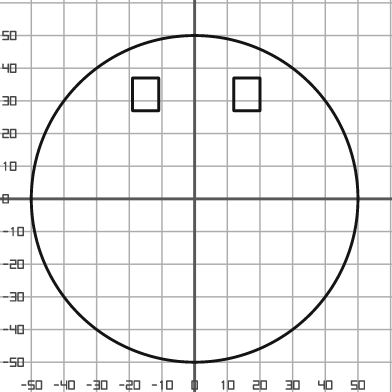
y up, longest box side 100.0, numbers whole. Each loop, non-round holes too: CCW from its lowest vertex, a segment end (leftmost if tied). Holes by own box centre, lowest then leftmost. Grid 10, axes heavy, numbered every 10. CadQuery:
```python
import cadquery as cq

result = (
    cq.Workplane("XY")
    .moveTo(0.0, 0.0)
    .circle(50.0)
    .moveTo(-19.0, 27.0)
    .lineTo(-11.0, 27.0)
    .lineTo(-11.0, 37.0)
    .lineTo(-19.0, 37.0)
    .close()
    .moveTo(12.0, 27.0)
    .lineTo(20.0, 27.0)
    .lineTo(20.0, 37.0)
    .lineTo(12.0, 37.0)
    .close()
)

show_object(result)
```